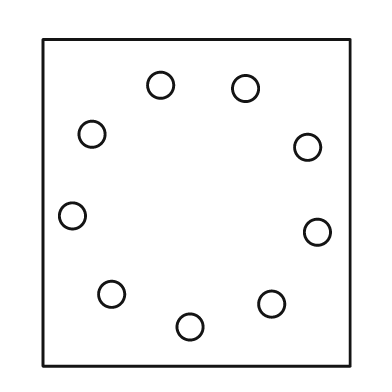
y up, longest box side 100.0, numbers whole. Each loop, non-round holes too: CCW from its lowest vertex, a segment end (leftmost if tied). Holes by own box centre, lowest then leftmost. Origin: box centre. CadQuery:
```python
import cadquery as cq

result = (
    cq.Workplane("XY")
    .moveTo(-47.0, -50.0)
    .lineTo(47.0, -50.0)
    .lineTo(47.0, 50.0)
    .lineTo(-47.0, 50.0)
    .close()
    .moveTo(-2.0, -38.0)
    .circle(4.0)
    .moveTo(23.0, -31.0)
    .circle(4.0)
    .moveTo(-26.0, -28.0)
    .circle(4.0)
    .moveTo(37.0, -9.0)
    .circle(4.0)
    .moveTo(-38.0, -4.0)
    .circle(4.0)
    .moveTo(34.0, 17.0)
    .circle(4.0)
    .moveTo(-32.0, 21.0)
    .circle(4.0)
    .moveTo(15.0, 35.0)
    .circle(4.0)
    .moveTo(-11.0, 36.0)
    .circle(4.0)
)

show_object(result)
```